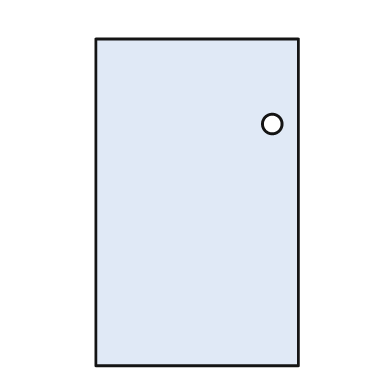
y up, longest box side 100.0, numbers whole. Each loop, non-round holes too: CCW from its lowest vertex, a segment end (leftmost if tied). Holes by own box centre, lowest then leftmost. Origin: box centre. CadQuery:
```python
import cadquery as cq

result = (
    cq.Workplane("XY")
    .moveTo(-31.0, -50.0)
    .lineTo(31.0, -50.0)
    .lineTo(31.0, 50.0)
    .lineTo(-31.0, 50.0)
    .close()
    .moveTo(23.0, 24.0)
    .circle(3.0)
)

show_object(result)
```